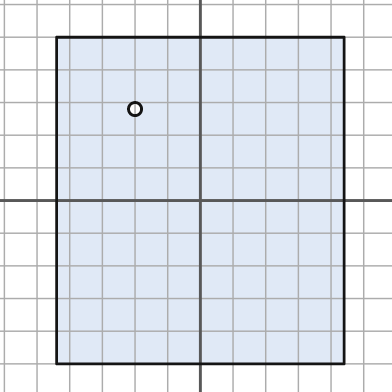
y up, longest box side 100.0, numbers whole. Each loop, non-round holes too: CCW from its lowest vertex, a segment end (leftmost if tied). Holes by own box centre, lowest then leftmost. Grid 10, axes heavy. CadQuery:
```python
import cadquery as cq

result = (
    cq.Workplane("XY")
    .moveTo(-44.0, -50.0)
    .lineTo(44.0, -50.0)
    .lineTo(44.0, 50.0)
    .lineTo(-44.0, 50.0)
    .close()
    .moveTo(-20.0, 28.0)
    .circle(2.0)
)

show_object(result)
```